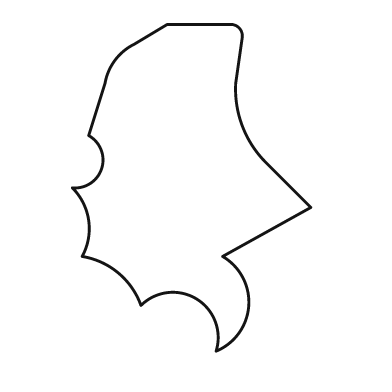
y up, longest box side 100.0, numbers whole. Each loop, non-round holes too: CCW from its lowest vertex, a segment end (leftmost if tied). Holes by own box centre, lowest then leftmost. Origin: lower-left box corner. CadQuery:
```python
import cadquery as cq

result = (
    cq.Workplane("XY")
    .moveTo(44.0, 0.0)
    .threePointArc((54.0, 14.0), (46.0, 29.0))
    .lineTo(73.0, 44.0)
    .lineTo(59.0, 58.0)
    .threePointArc((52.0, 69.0), (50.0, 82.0))
    .lineTo(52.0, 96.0)
    .threePointArc((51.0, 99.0), (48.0, 100.0))
    .lineTo(29.0, 100.0)
    .lineTo(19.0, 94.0)
    .threePointArc((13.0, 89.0), (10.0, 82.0))
    .lineTo(5.0, 66.0)
    .threePointArc((9.0, 56.0), (0.0, 50.0))
    .threePointArc((5.0, 40.0), (3.0, 29.0))
    .threePointArc((14.0, 24.0), (21.0, 14.0))
    .threePointArc((38.0, 16.0), (44.0, 0.0))
    .close()
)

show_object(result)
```